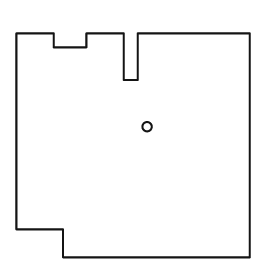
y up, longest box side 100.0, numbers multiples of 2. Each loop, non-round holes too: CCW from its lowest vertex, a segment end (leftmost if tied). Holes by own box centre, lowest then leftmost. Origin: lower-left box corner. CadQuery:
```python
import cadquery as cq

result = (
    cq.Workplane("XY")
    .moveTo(20.0, 0.0)
    .lineTo(100.0, 0.0)
    .lineTo(100.0, 96.0)
    .lineTo(52.0, 96.0)
    .lineTo(52.0, 76.0)
    .lineTo(46.0, 76.0)
    .lineTo(46.0, 96.0)
    .lineTo(30.0, 96.0)
    .lineTo(30.0, 90.0)
    .lineTo(16.0, 90.0)
    .lineTo(16.0, 96.0)
    .lineTo(0.0, 96.0)
    .lineTo(0.0, 12.0)
    .lineTo(20.0, 12.0)
    .close()
    .moveTo(56.0, 56.0)
    .circle(2.0)
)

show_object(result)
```